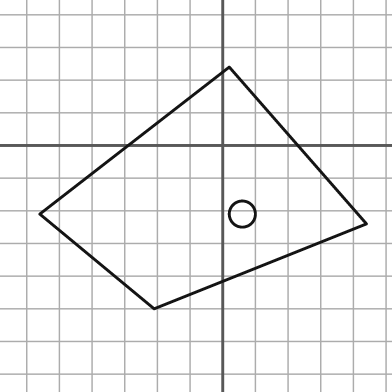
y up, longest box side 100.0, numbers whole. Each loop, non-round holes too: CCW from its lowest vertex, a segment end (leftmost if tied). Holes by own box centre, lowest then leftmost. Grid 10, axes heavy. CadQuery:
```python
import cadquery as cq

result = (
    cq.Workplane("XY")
    .moveTo(-21.0, -50.0)
    .lineTo(44.0, -24.0)
    .lineTo(2.0, 24.0)
    .lineTo(-56.0, -21.0)
    .close()
    .moveTo(6.0, -21.0)
    .circle(4.0)
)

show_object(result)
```